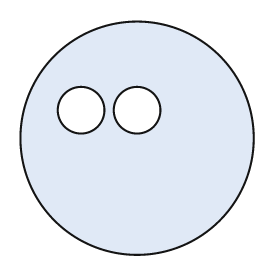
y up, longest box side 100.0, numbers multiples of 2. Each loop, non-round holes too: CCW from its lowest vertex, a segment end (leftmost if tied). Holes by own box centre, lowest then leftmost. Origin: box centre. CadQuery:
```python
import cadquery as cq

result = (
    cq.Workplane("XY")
    .moveTo(0.0, 0.0)
    .circle(50.0)
    .moveTo(-24.0, 12.0)
    .circle(10.0)
    .moveTo(0.0, 12.0)
    .circle(10.0)
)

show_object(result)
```